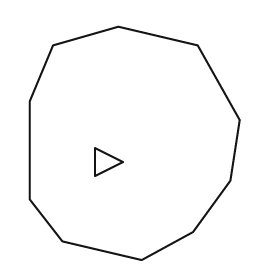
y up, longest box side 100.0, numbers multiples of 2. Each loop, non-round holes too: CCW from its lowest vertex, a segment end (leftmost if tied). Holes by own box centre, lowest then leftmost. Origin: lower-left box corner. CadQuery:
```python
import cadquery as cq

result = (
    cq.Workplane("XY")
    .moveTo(48.0, 0.0)
    .lineTo(70.0, 12.0)
    .lineTo(86.0, 34.0)
    .lineTo(90.0, 60.0)
    .lineTo(72.0, 92.0)
    .lineTo(38.0, 100.0)
    .lineTo(10.0, 92.0)
    .lineTo(0.0, 68.0)
    .lineTo(0.0, 26.0)
    .lineTo(14.0, 8.0)
    .close()
    .moveTo(28.0, 36.0)
    .lineTo(40.0, 42.0)
    .lineTo(28.0, 48.0)
    .close()
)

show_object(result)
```